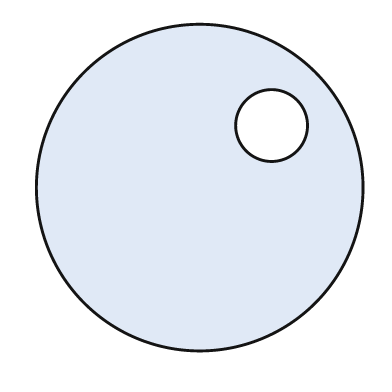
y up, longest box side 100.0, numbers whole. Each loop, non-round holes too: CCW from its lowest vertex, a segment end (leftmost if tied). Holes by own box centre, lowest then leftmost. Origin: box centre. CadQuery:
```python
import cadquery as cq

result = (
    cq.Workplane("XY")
    .moveTo(0.0, 0.0)
    .circle(50.0)
    .moveTo(22.0, 19.0)
    .circle(11.0)
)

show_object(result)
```